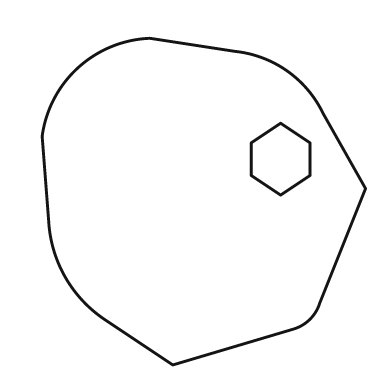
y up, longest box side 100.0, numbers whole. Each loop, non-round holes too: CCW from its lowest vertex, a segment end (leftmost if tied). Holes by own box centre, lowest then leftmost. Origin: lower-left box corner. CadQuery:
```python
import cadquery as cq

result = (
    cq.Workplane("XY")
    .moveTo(40.0, 0.0)
    .lineTo(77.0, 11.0)
    .threePointArc((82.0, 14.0), (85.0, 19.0))
    .lineTo(99.0, 54.0)
    .lineTo(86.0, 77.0)
    .threePointArc((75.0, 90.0), (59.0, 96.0))
    .lineTo(33.0, 100.0)
    .threePointArc((11.0, 91.0), (0.0, 70.0))
    .lineTo(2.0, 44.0)
    .threePointArc((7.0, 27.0), (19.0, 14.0))
    .close()
    .moveTo(73.0, 52.0)
    .lineTo(82.0, 58.0)
    .lineTo(82.0, 68.0)
    .lineTo(73.0, 74.0)
    .lineTo(64.0, 68.0)
    .lineTo(64.0, 58.0)
    .close()
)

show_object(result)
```